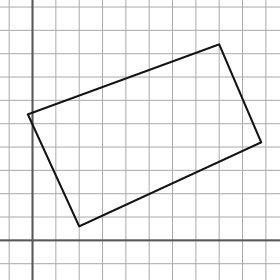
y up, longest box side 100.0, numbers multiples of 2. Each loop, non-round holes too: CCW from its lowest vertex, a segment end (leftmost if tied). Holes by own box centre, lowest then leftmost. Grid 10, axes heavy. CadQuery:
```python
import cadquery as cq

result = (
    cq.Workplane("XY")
    .moveTo(20.0, 6.0)
    .lineTo(98.0, 42.0)
    .lineTo(80.0, 84.0)
    .lineTo(-2.0, 54.0)
    .close()
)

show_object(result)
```